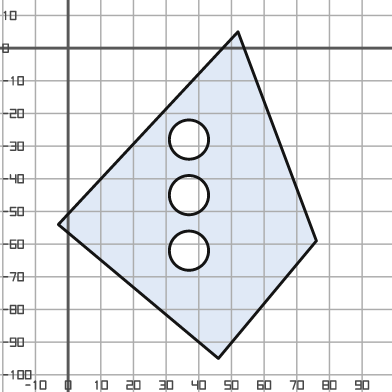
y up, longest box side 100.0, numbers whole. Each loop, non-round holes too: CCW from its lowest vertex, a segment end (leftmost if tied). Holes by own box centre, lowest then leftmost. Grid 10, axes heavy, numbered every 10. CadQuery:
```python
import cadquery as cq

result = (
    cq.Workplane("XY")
    .moveTo(46.0, -95.0)
    .lineTo(76.0, -59.0)
    .lineTo(52.0, 5.0)
    .lineTo(-3.0, -54.0)
    .close()
    .moveTo(37.0, -62.0)
    .circle(6.0)
    .moveTo(37.0, -45.0)
    .circle(6.0)
    .moveTo(37.0, -28.0)
    .circle(6.0)
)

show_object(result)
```